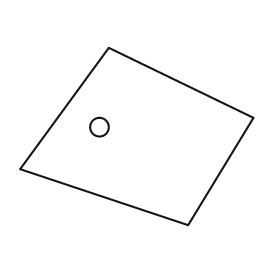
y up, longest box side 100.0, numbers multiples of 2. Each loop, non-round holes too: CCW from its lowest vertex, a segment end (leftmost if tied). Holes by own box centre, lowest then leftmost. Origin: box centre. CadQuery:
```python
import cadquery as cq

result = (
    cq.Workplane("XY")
    .moveTo(22.0, -38.0)
    .lineTo(50.0, 8.0)
    .lineTo(-12.0, 38.0)
    .lineTo(-50.0, -14.0)
    .close()
    .moveTo(-16.0, 4.0)
    .circle(4.0)
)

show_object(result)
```